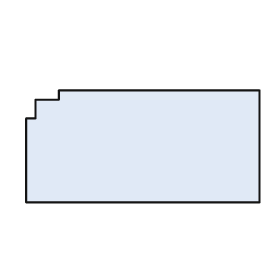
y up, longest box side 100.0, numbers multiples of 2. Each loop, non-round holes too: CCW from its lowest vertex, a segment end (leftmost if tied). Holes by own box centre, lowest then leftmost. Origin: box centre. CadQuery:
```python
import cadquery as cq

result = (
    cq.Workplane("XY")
    .moveTo(-50.0, -24.0)
    .lineTo(50.0, -24.0)
    .lineTo(50.0, 24.0)
    .lineTo(-36.0, 24.0)
    .lineTo(-36.0, 20.0)
    .lineTo(-46.0, 20.0)
    .lineTo(-46.0, 12.0)
    .lineTo(-50.0, 12.0)
    .close()
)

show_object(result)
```